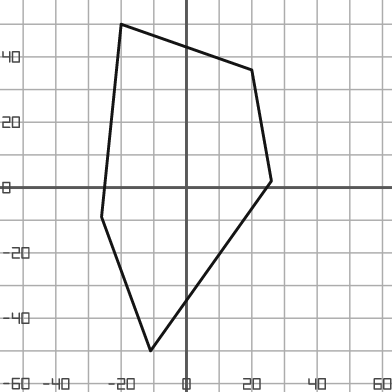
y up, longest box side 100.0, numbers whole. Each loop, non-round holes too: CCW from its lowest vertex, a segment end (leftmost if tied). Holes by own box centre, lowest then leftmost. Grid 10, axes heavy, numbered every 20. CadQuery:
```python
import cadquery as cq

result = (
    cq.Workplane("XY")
    .moveTo(-11.0, -50.0)
    .lineTo(26.0, 2.0)
    .lineTo(20.0, 36.0)
    .lineTo(-20.0, 50.0)
    .lineTo(-26.0, -9.0)
    .close()
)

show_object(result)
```